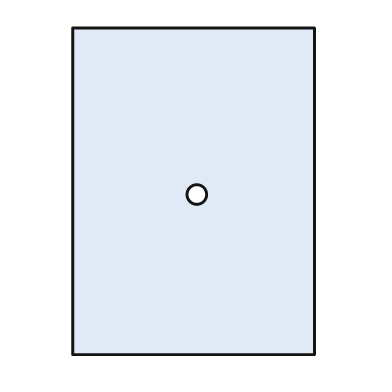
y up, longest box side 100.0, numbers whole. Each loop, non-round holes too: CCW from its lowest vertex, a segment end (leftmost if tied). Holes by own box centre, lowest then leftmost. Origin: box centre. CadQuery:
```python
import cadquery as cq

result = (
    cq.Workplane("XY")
    .moveTo(-37.0, -50.0)
    .lineTo(37.0, -50.0)
    .lineTo(37.0, 50.0)
    .lineTo(-37.0, 50.0)
    .close()
    .moveTo(1.0, -1.0)
    .circle(3.0)
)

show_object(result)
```